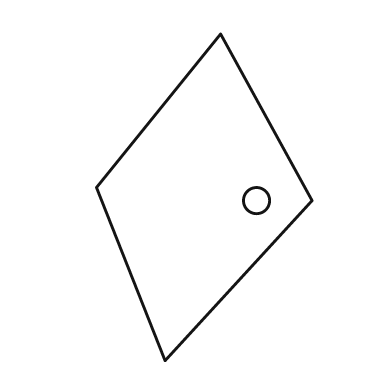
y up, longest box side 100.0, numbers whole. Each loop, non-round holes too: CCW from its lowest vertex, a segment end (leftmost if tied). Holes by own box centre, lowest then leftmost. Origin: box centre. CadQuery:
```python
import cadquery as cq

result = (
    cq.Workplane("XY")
    .moveTo(-12.0, -50.0)
    .lineTo(33.0, -1.0)
    .lineTo(5.0, 50.0)
    .lineTo(-33.0, 3.0)
    .close()
    .moveTo(16.0, -1.0)
    .circle(4.0)
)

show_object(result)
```